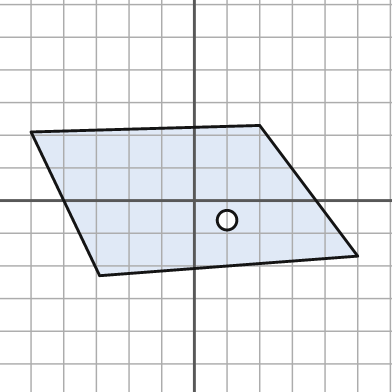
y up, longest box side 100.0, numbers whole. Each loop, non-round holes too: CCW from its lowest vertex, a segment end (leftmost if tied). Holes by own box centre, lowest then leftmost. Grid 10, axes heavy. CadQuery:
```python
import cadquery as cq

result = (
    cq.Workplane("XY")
    .moveTo(-29.0, -23.0)
    .lineTo(50.0, -17.0)
    .lineTo(20.0, 23.0)
    .lineTo(-50.0, 21.0)
    .close()
    .moveTo(10.0, -6.0)
    .circle(3.0)
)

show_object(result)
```